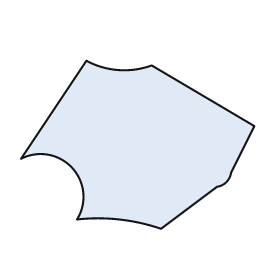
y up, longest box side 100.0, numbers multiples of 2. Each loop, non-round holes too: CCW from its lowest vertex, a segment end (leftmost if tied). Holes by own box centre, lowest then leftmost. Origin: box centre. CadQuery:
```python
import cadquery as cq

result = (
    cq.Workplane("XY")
    .moveTo(10.0, -36.0)
    .lineTo(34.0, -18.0)
    .threePointArc((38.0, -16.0), (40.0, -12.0))
    .lineTo(50.0, 8.0)
    .lineTo(6.0, 34.0)
    .threePointArc((-8.0, 32.0), (-22.0, 36.0))
    .lineTo(-50.0, -6.0)
    .threePointArc((-28.0, -10.0), (-26.0, -32.0))
    .threePointArc((-8.0, -32.0), (10.0, -36.0))
    .close()
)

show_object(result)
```